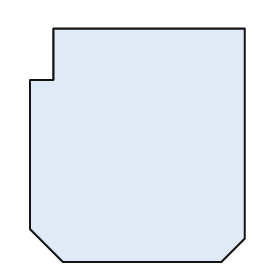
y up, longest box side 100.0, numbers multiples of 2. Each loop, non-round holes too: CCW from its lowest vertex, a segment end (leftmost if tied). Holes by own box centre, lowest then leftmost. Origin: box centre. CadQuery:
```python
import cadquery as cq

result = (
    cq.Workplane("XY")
    .moveTo(-32.0, -50.0)
    .lineTo(36.0, -50.0)
    .lineTo(46.0, -40.0)
    .lineTo(46.0, 50.0)
    .lineTo(-36.0, 50.0)
    .lineTo(-36.0, 28.0)
    .lineTo(-46.0, 28.0)
    .lineTo(-46.0, -36.0)
    .close()
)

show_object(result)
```